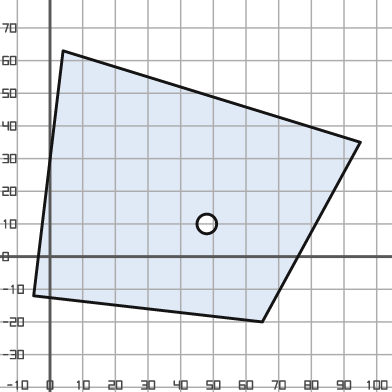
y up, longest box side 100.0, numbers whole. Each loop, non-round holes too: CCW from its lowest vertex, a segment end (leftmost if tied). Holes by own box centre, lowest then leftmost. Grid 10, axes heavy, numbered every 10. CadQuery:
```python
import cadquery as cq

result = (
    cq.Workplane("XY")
    .moveTo(65.0, -20.0)
    .lineTo(95.0, 35.0)
    .lineTo(4.0, 63.0)
    .lineTo(-5.0, -12.0)
    .close()
    .moveTo(48.0, 10.0)
    .circle(3.0)
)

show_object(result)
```